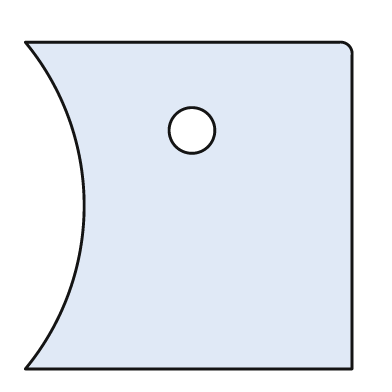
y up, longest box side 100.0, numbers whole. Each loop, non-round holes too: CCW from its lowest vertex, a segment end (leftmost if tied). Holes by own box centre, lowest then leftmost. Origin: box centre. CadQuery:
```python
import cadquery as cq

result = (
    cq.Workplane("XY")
    .moveTo(-50.0, -50.0)
    .lineTo(50.0, -50.0)
    .lineTo(50.0, 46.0)
    .threePointArc((49.0, 49.0), (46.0, 50.0))
    .lineTo(-50.0, 50.0)
    .threePointArc((-32.0, 0.0), (-50.0, -50.0))
    .close()
    .moveTo(1.0, 23.0)
    .circle(7.0)
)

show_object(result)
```